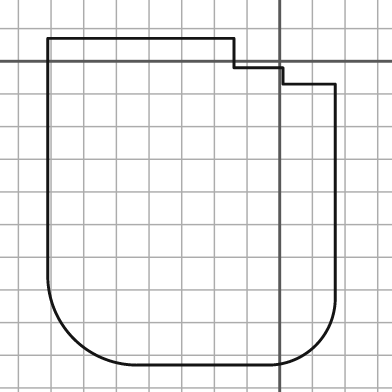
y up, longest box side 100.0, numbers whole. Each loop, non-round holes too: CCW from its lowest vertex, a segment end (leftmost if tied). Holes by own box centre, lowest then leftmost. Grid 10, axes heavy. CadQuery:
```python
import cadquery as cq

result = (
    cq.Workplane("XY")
    .moveTo(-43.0, -93.0)
    .lineTo(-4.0, -93.0)
    .threePointArc((11.0, -87.0), (17.0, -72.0))
    .lineTo(17.0, -7.0)
    .lineTo(1.0, -7.0)
    .lineTo(1.0, -2.0)
    .lineTo(-14.0, -2.0)
    .lineTo(-14.0, 7.0)
    .lineTo(-71.0, 7.0)
    .lineTo(-71.0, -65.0)
    .threePointArc((-63.0, -85.0), (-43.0, -93.0))
    .close()
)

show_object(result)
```